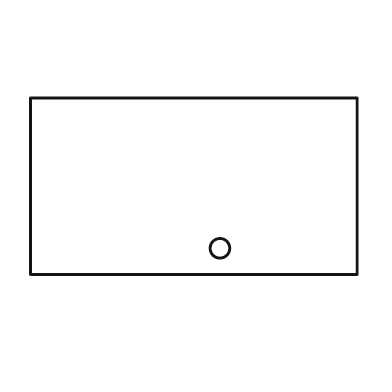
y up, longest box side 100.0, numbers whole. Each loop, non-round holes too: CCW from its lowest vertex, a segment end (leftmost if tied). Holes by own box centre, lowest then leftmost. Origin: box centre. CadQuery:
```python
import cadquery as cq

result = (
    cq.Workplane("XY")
    .moveTo(-50.0, -27.0)
    .lineTo(50.0, -27.0)
    .lineTo(50.0, 27.0)
    .lineTo(-50.0, 27.0)
    .close()
    .moveTo(8.0, -19.0)
    .circle(3.0)
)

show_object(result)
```